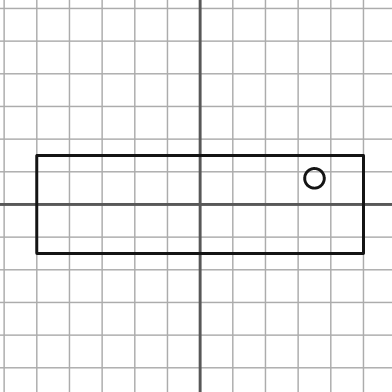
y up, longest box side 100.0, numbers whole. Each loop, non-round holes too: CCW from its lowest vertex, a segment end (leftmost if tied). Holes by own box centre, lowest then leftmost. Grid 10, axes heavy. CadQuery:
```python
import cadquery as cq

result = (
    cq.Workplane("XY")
    .moveTo(-50.0, -15.0)
    .lineTo(50.0, -15.0)
    .lineTo(50.0, 15.0)
    .lineTo(-50.0, 15.0)
    .close()
    .moveTo(35.0, 8.0)
    .circle(3.0)
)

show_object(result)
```